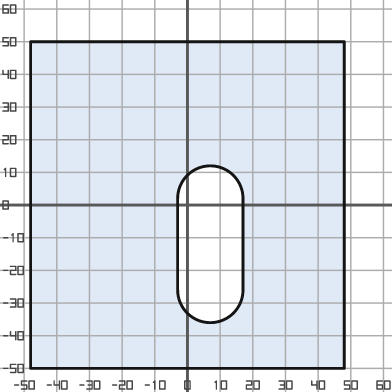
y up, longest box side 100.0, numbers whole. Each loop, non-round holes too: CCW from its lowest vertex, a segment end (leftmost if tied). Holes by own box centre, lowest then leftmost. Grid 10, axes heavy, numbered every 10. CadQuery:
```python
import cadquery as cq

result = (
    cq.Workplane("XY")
    .moveTo(-48.0, -50.0)
    .lineTo(48.0, -50.0)
    .lineTo(48.0, 50.0)
    .lineTo(-48.0, 50.0)
    .close()
    .moveTo(-3.0, -26.0)
    .threePointArc((7.0, -36.0), (17.0, -26.0))
    .lineTo(17.0, 2.0)
    .threePointArc((7.0, 12.0), (-3.0, 2.0))
    .close()
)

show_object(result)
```